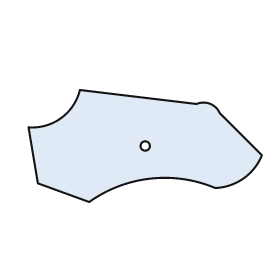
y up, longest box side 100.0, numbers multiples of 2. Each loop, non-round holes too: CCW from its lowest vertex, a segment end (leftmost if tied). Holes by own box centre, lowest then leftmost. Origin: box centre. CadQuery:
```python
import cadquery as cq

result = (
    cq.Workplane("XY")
    .moveTo(-24.0, -24.0)
    .threePointArc((2.0, -14.0), (30.0, -18.0))
    .threePointArc((42.0, -14.0), (50.0, -4.0))
    .lineTo(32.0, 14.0)
    .threePointArc((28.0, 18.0), (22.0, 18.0))
    .lineTo(-28.0, 24.0)
    .threePointArc((-36.0, 12.0), (-50.0, 8.0))
    .lineTo(-46.0, -16.0)
    .close()
    .moveTo(0.0, 0.0)
    .circle(2.0)
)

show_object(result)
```